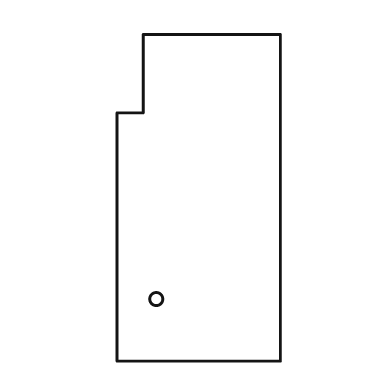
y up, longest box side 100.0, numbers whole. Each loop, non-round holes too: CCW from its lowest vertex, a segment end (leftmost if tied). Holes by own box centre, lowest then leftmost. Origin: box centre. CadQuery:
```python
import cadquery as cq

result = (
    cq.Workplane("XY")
    .moveTo(-25.0, -50.0)
    .lineTo(25.0, -50.0)
    .lineTo(25.0, 50.0)
    .lineTo(-17.0, 50.0)
    .lineTo(-17.0, 26.0)
    .lineTo(-25.0, 26.0)
    .close()
    .moveTo(-13.0, -31.0)
    .circle(2.0)
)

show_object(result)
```